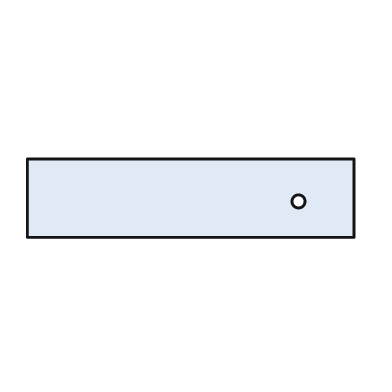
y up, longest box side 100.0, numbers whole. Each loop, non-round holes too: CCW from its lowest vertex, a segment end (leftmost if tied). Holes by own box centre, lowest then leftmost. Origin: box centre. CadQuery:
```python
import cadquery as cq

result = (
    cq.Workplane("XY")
    .moveTo(-50.0, -12.0)
    .lineTo(50.0, -12.0)
    .lineTo(50.0, 12.0)
    .lineTo(-50.0, 12.0)
    .close()
    .moveTo(33.0, -1.0)
    .circle(2.0)
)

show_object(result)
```